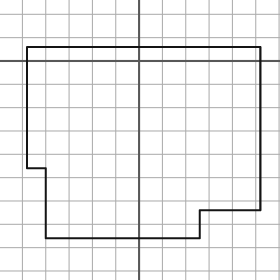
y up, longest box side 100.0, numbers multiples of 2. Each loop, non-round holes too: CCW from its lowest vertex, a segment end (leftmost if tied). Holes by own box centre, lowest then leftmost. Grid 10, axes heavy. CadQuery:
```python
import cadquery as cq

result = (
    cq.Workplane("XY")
    .moveTo(-40.0, -76.0)
    .lineTo(26.0, -76.0)
    .lineTo(26.0, -64.0)
    .lineTo(52.0, -64.0)
    .lineTo(52.0, 6.0)
    .lineTo(-48.0, 6.0)
    .lineTo(-48.0, -46.0)
    .lineTo(-40.0, -46.0)
    .close()
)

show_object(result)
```